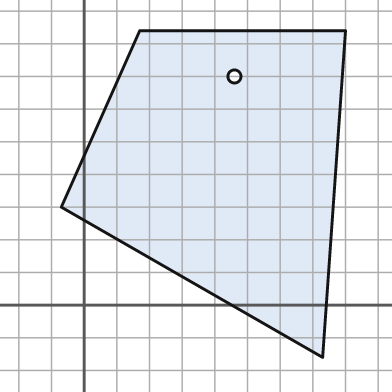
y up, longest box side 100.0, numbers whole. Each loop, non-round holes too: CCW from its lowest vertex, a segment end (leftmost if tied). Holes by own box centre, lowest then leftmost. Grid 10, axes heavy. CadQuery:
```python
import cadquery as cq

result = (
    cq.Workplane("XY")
    .moveTo(73.0, -16.0)
    .lineTo(80.0, 84.0)
    .lineTo(17.0, 84.0)
    .lineTo(-7.0, 30.0)
    .close()
    .moveTo(46.0, 70.0)
    .circle(2.0)
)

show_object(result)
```